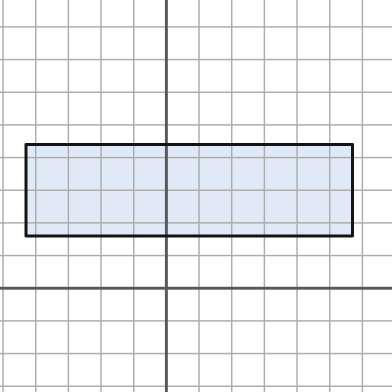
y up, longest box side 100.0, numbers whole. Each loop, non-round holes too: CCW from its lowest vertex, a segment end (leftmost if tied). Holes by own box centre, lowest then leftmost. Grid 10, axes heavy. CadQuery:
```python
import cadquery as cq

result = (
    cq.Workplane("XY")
    .moveTo(-43.0, 16.0)
    .lineTo(57.0, 16.0)
    .lineTo(57.0, 44.0)
    .lineTo(-43.0, 44.0)
    .close()
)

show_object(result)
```